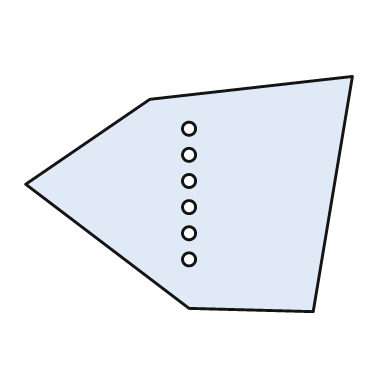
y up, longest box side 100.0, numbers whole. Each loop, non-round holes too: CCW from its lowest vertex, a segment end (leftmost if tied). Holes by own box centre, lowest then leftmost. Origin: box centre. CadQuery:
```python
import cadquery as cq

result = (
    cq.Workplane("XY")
    .moveTo(38.0, -36.0)
    .lineTo(50.0, 36.0)
    .lineTo(-12.0, 29.0)
    .lineTo(-50.0, 3.0)
    .lineTo(0.0, -35.0)
    .close()
    .moveTo(0.0, -20.0)
    .circle(2.0)
    .moveTo(0.0, -12.0)
    .circle(2.0)
    .moveTo(0.0, -4.0)
    .circle(2.0)
    .moveTo(0.0, 4.0)
    .circle(2.0)
    .moveTo(0.0, 12.0)
    .circle(2.0)
    .moveTo(0.0, 20.0)
    .circle(2.0)
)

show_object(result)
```